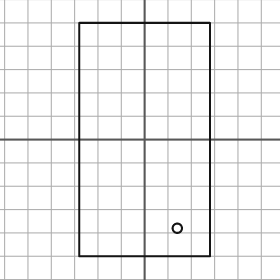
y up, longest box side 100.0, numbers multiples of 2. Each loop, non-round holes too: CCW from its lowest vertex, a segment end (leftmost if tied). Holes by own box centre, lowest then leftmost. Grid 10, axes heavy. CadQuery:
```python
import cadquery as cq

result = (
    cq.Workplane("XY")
    .moveTo(-28.0, -50.0)
    .lineTo(28.0, -50.0)
    .lineTo(28.0, 50.0)
    .lineTo(-28.0, 50.0)
    .close()
    .moveTo(14.0, -38.0)
    .circle(2.0)
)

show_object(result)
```